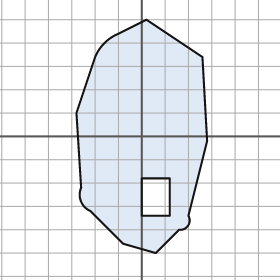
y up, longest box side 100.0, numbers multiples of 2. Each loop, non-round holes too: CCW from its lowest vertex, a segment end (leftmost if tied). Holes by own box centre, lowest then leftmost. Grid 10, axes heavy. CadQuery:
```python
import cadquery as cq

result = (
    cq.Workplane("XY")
    .moveTo(6.0, -50.0)
    .lineTo(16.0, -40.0)
    .threePointArc((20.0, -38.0), (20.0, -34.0))
    .lineTo(28.0, -2.0)
    .lineTo(26.0, 34.0)
    .lineTo(2.0, 50.0)
    .lineTo(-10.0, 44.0)
    .threePointArc((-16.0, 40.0), (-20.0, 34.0))
    .lineTo(-28.0, 10.0)
    .lineTo(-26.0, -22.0)
    .threePointArc((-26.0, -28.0), (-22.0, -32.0))
    .lineTo(-8.0, -46.0)
    .close()
    .moveTo(0.0, -34.0)
    .lineTo(12.0, -34.0)
    .lineTo(12.0, -18.0)
    .lineTo(0.0, -18.0)
    .close()
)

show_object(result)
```